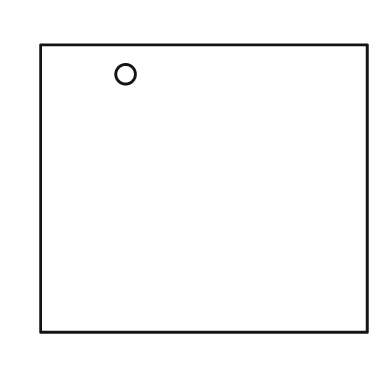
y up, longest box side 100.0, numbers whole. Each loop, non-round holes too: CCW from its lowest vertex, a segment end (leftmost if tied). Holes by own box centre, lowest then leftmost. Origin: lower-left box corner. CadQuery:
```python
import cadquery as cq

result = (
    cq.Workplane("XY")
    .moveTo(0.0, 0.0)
    .lineTo(100.0, 0.0)
    .lineTo(100.0, 88.0)
    .lineTo(0.0, 88.0)
    .close()
    .moveTo(26.0, 79.0)
    .circle(3.0)
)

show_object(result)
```